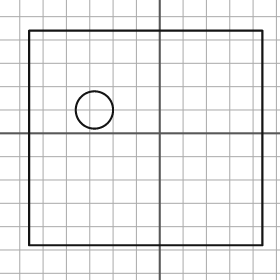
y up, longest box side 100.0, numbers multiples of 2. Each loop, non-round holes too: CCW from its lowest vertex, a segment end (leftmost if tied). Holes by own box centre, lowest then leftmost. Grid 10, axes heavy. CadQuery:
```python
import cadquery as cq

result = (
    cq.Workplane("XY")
    .moveTo(-56.0, -48.0)
    .lineTo(44.0, -48.0)
    .lineTo(44.0, 44.0)
    .lineTo(-56.0, 44.0)
    .close()
    .moveTo(-28.0, 10.0)
    .circle(8.0)
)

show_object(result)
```